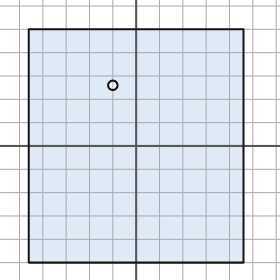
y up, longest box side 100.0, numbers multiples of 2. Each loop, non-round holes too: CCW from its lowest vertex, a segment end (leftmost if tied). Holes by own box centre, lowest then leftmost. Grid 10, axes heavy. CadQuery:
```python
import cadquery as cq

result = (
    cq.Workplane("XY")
    .moveTo(-46.0, -50.0)
    .lineTo(46.0, -50.0)
    .lineTo(46.0, 50.0)
    .lineTo(-46.0, 50.0)
    .close()
    .moveTo(-10.0, 26.0)
    .circle(2.0)
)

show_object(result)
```